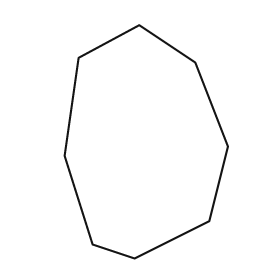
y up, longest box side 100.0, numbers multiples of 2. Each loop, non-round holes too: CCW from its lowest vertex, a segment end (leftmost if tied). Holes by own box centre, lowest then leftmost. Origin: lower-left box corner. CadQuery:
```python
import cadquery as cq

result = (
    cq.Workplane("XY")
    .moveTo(30.0, 0.0)
    .lineTo(62.0, 16.0)
    .lineTo(70.0, 48.0)
    .lineTo(56.0, 84.0)
    .lineTo(32.0, 100.0)
    .lineTo(6.0, 86.0)
    .lineTo(0.0, 44.0)
    .lineTo(12.0, 6.0)
    .close()
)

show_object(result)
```